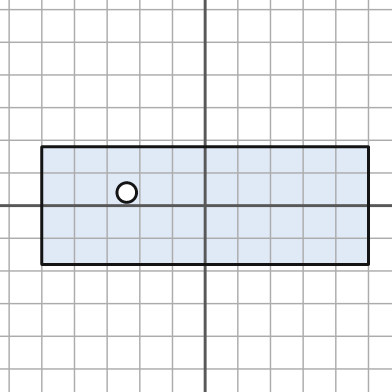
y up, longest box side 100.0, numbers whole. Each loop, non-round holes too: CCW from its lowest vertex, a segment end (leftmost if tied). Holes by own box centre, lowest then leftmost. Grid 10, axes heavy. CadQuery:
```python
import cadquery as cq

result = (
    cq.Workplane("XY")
    .moveTo(-50.0, -18.0)
    .lineTo(50.0, -18.0)
    .lineTo(50.0, 18.0)
    .lineTo(-50.0, 18.0)
    .close()
    .moveTo(-24.0, 4.0)
    .circle(3.0)
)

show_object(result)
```